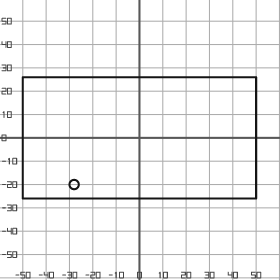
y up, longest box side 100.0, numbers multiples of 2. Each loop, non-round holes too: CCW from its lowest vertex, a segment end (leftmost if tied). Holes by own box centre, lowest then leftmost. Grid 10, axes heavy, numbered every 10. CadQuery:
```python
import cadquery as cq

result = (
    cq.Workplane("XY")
    .moveTo(-50.0, -26.0)
    .lineTo(50.0, -26.0)
    .lineTo(50.0, 26.0)
    .lineTo(-50.0, 26.0)
    .close()
    .moveTo(-28.0, -20.0)
    .circle(2.0)
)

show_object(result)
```